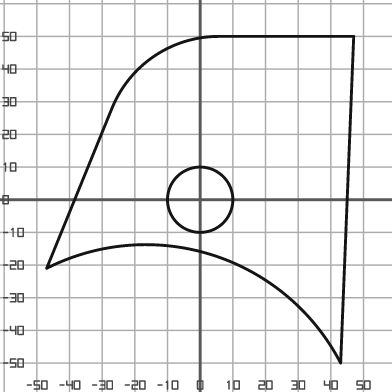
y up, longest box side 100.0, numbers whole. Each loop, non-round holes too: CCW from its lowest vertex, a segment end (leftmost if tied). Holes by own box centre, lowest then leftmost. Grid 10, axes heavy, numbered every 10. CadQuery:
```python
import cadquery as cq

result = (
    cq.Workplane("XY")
    .moveTo(43.0, -50.0)
    .lineTo(47.0, 50.0)
    .lineTo(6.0, 50.0)
    .threePointArc((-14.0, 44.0), (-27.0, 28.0))
    .lineTo(-47.0, -21.0)
    .threePointArc((4.0, -17.0), (43.0, -50.0))
    .close()
    .moveTo(0.0, 0.0)
    .circle(10.0)
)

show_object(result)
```